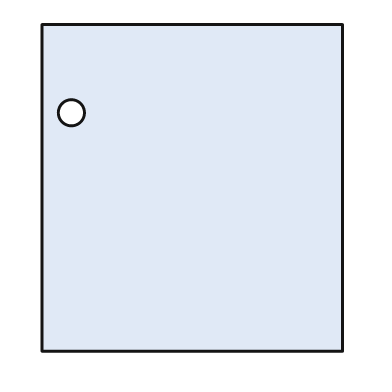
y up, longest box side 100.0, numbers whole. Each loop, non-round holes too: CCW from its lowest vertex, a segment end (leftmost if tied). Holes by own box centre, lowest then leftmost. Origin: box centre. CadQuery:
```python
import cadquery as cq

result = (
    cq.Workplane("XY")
    .moveTo(-46.0, -50.0)
    .lineTo(46.0, -50.0)
    .lineTo(46.0, 50.0)
    .lineTo(-46.0, 50.0)
    .close()
    .moveTo(-37.0, 23.0)
    .circle(4.0)
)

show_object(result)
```